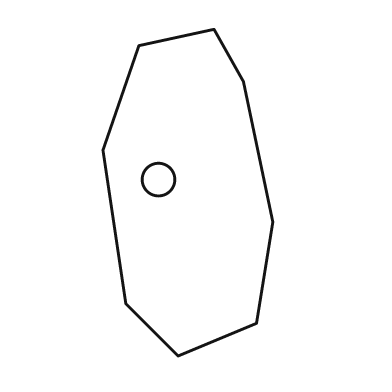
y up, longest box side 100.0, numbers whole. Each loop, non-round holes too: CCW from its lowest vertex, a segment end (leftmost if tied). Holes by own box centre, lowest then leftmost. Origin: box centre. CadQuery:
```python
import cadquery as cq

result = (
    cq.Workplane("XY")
    .moveTo(-3.0, -50.0)
    .lineTo(21.0, -40.0)
    .lineTo(26.0, -9.0)
    .lineTo(17.0, 34.0)
    .lineTo(8.0, 50.0)
    .lineTo(-15.0, 45.0)
    .lineTo(-26.0, 13.0)
    .lineTo(-19.0, -34.0)
    .close()
    .moveTo(-9.0, 4.0)
    .circle(5.0)
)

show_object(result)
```